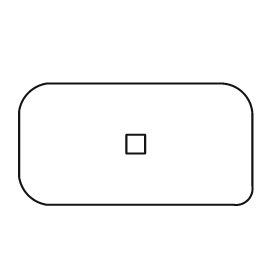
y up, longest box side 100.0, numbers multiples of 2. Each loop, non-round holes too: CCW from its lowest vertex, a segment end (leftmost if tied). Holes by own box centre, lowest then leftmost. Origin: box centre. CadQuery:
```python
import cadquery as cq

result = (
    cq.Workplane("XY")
    .moveTo(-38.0, -26.0)
    .lineTo(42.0, -26.0)
    .threePointArc((48.0, -24.0), (50.0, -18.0))
    .lineTo(50.0, 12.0)
    .threePointArc((46.0, 22.0), (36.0, 26.0))
    .lineTo(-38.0, 26.0)
    .threePointArc((-46.0, 22.0), (-50.0, 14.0))
    .lineTo(-50.0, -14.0)
    .threePointArc((-46.0, -22.0), (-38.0, -26.0))
    .close()
    .moveTo(-4.0, -4.0)
    .lineTo(4.0, -4.0)
    .lineTo(4.0, 4.0)
    .lineTo(-4.0, 4.0)
    .close()
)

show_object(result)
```